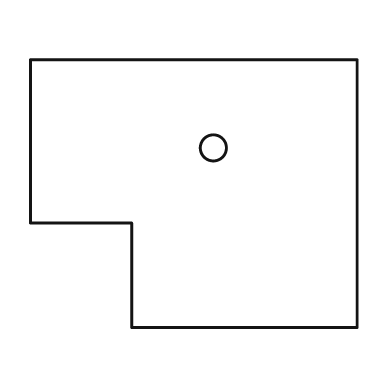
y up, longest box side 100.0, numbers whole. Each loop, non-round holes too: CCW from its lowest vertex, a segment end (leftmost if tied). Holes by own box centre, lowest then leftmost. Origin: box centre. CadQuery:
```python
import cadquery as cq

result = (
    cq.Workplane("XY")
    .moveTo(-19.0, -41.0)
    .lineTo(50.0, -41.0)
    .lineTo(50.0, 41.0)
    .lineTo(-50.0, 41.0)
    .lineTo(-50.0, -9.0)
    .lineTo(-19.0, -9.0)
    .close()
    .moveTo(6.0, 14.0)
    .circle(4.0)
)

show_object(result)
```